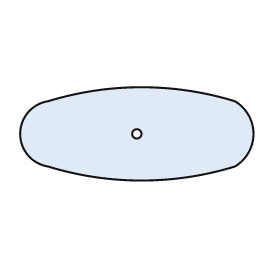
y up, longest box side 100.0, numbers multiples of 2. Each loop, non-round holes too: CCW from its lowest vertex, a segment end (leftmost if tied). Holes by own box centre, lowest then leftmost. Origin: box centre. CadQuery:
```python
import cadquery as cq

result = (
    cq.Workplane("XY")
    .moveTo(-38.0, -14.0)
    .threePointArc((2.0, -20.0), (42.0, -14.0))
    .threePointArc((50.0, 0.0), (42.0, 14.0))
    .threePointArc((2.0, 20.0), (-38.0, 14.0))
    .threePointArc((-50.0, 0.0), (-38.0, -14.0))
    .close()
    .moveTo(0.0, 0.0)
    .circle(2.0)
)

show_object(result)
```